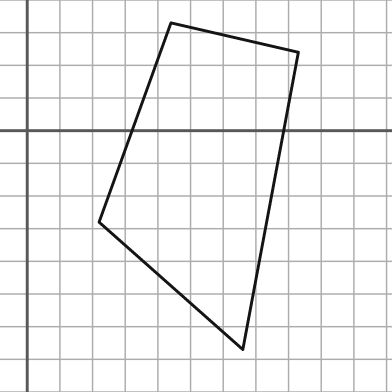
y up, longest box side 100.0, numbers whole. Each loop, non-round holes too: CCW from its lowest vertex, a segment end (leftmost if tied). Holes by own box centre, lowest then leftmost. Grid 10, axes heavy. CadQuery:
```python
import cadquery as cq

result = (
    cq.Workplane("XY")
    .moveTo(66.0, -67.0)
    .lineTo(83.0, 24.0)
    .lineTo(44.0, 33.0)
    .lineTo(22.0, -28.0)
    .close()
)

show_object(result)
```